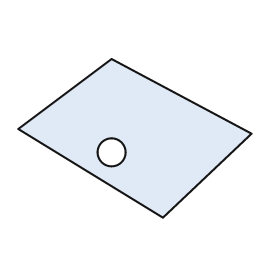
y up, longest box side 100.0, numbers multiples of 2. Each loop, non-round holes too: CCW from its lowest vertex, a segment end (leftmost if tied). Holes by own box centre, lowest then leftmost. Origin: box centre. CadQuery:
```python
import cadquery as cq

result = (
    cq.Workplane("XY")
    .moveTo(12.0, -34.0)
    .lineTo(50.0, 2.0)
    .lineTo(-10.0, 34.0)
    .lineTo(-50.0, 4.0)
    .close()
    .moveTo(-10.0, -6.0)
    .circle(6.0)
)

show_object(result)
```